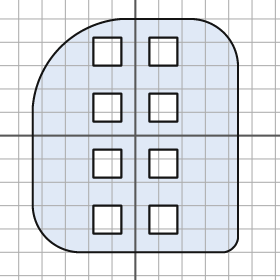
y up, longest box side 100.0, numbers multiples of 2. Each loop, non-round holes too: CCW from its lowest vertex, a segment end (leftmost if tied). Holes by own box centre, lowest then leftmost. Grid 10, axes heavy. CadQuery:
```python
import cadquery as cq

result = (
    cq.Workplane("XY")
    .moveTo(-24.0, -50.0)
    .lineTo(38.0, -50.0)
    .threePointArc((42.0, -48.0), (44.0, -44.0))
    .lineTo(44.0, 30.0)
    .threePointArc((38.0, 44.0), (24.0, 50.0))
    .lineTo(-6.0, 50.0)
    .threePointArc((-32.0, 38.0), (-44.0, 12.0))
    .lineTo(-44.0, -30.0)
    .threePointArc((-38.0, -44.0), (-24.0, -50.0))
    .close()
    .moveTo(-18.0, -42.0)
    .lineTo(-6.0, -42.0)
    .lineTo(-6.0, -30.0)
    .lineTo(-18.0, -30.0)
    .close()
    .moveTo(6.0, -42.0)
    .lineTo(18.0, -42.0)
    .lineTo(18.0, -30.0)
    .lineTo(6.0, -30.0)
    .close()
    .moveTo(-18.0, -18.0)
    .lineTo(-6.0, -18.0)
    .lineTo(-6.0, -6.0)
    .lineTo(-18.0, -6.0)
    .close()
    .moveTo(6.0, -18.0)
    .lineTo(18.0, -18.0)
    .lineTo(18.0, -6.0)
    .lineTo(6.0, -6.0)
    .close()
    .moveTo(-18.0, 6.0)
    .lineTo(-6.0, 6.0)
    .lineTo(-6.0, 18.0)
    .lineTo(-18.0, 18.0)
    .close()
    .moveTo(6.0, 6.0)
    .lineTo(18.0, 6.0)
    .lineTo(18.0, 18.0)
    .lineTo(6.0, 18.0)
    .close()
    .moveTo(-18.0, 30.0)
    .lineTo(-6.0, 30.0)
    .lineTo(-6.0, 42.0)
    .lineTo(-18.0, 42.0)
    .close()
    .moveTo(6.0, 30.0)
    .lineTo(18.0, 30.0)
    .lineTo(18.0, 42.0)
    .lineTo(6.0, 42.0)
    .close()
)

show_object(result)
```